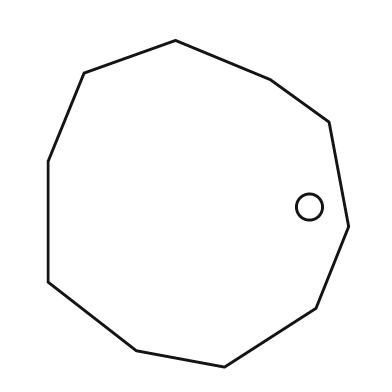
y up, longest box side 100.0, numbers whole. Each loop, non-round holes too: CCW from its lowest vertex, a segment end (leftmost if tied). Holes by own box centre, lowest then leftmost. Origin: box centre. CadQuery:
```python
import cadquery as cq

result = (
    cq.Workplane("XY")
    .moveTo(8.0, -50.0)
    .lineTo(36.0, -32.0)
    .lineTo(46.0, -7.0)
    .lineTo(40.0, 25.0)
    .lineTo(22.0, 38.0)
    .lineTo(-7.0, 50.0)
    .lineTo(-35.0, 40.0)
    .lineTo(-46.0, 13.0)
    .lineTo(-46.0, -24.0)
    .lineTo(-19.0, -45.0)
    .close()
    .moveTo(34.0, -1.0)
    .circle(4.0)
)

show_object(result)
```